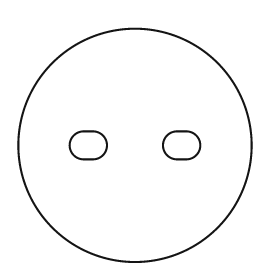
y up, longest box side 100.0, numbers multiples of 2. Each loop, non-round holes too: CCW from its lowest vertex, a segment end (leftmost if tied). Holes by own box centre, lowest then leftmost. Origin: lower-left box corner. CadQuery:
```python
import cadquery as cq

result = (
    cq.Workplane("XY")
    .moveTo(50.0, 50.0)
    .circle(50.0)
    .moveTo(28.0, 44.0)
    .lineTo(32.0, 44.0)
    .threePointArc((38.0, 50.0), (32.0, 56.0))
    .lineTo(28.0, 56.0)
    .threePointArc((22.0, 50.0), (28.0, 44.0))
    .close()
    .moveTo(68.0, 44.0)
    .lineTo(72.0, 44.0)
    .threePointArc((78.0, 50.0), (72.0, 56.0))
    .lineTo(68.0, 56.0)
    .threePointArc((62.0, 50.0), (68.0, 44.0))
    .close()
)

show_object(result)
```